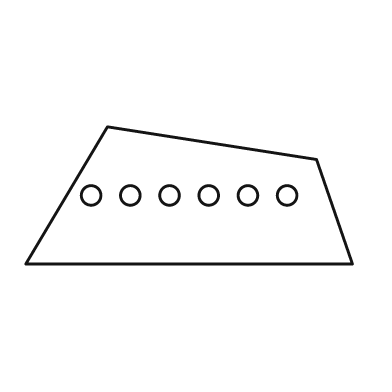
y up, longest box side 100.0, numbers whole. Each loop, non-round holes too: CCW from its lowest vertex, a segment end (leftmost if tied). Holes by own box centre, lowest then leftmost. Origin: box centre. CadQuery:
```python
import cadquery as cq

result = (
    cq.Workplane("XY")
    .moveTo(-50.0, -21.0)
    .lineTo(50.0, -21.0)
    .lineTo(39.0, 11.0)
    .lineTo(-25.0, 21.0)
    .close()
    .moveTo(-30.0, 0.0)
    .circle(3.0)
    .moveTo(-18.0, 0.0)
    .circle(3.0)
    .moveTo(-6.0, 0.0)
    .circle(3.0)
    .moveTo(6.0, 0.0)
    .circle(3.0)
    .moveTo(18.0, 0.0)
    .circle(3.0)
    .moveTo(30.0, 0.0)
    .circle(3.0)
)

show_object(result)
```